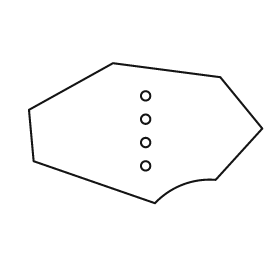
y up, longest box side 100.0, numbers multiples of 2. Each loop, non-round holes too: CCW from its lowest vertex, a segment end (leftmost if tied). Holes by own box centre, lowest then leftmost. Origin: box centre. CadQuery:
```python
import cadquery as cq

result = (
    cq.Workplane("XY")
    .moveTo(4.0, -30.0)
    .threePointArc((16.0, -22.0), (30.0, -20.0))
    .lineTo(50.0, 2.0)
    .lineTo(32.0, 24.0)
    .lineTo(-14.0, 30.0)
    .lineTo(-50.0, 10.0)
    .lineTo(-48.0, -12.0)
    .close()
    .moveTo(0.0, -14.0)
    .circle(2.0)
    .moveTo(0.0, -4.0)
    .circle(2.0)
    .moveTo(0.0, 6.0)
    .circle(2.0)
    .moveTo(0.0, 16.0)
    .circle(2.0)
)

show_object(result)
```